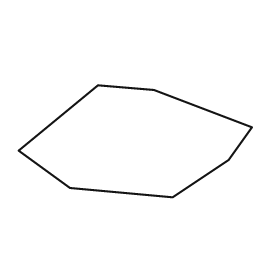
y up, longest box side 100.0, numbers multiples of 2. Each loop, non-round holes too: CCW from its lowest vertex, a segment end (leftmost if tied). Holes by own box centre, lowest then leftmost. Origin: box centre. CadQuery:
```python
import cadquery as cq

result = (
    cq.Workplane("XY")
    .moveTo(16.0, -24.0)
    .lineTo(40.0, -8.0)
    .lineTo(50.0, 6.0)
    .lineTo(8.0, 22.0)
    .lineTo(-16.0, 24.0)
    .lineTo(-50.0, -4.0)
    .lineTo(-28.0, -20.0)
    .close()
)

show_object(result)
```